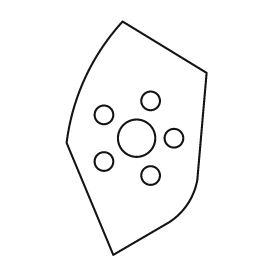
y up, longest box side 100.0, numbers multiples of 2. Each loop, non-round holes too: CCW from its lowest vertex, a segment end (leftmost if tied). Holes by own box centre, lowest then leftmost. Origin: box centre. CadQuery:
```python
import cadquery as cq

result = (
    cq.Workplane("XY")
    .moveTo(-10.0, -50.0)
    .lineTo(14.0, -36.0)
    .threePointArc((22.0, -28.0), (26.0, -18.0))
    .lineTo(30.0, 28.0)
    .lineTo(-6.0, 50.0)
    .threePointArc((-22.0, 26.0), (-30.0, -2.0))
    .close()
    .moveTo(6.0, -16.0)
    .circle(4.0)
    .moveTo(-14.0, -10.0)
    .circle(4.0)
    .moveTo(0.0, 0.0)
    .circle(8.0)
    .moveTo(16.0, 0.0)
    .circle(4.0)
    .moveTo(-14.0, 10.0)
    .circle(4.0)
    .moveTo(6.0, 16.0)
    .circle(4.0)
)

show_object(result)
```